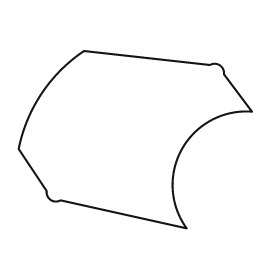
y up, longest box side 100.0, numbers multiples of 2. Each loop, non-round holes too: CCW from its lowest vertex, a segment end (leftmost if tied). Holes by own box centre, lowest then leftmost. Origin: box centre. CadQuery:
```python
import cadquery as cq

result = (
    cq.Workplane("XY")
    .moveTo(22.0, -38.0)
    .threePointArc((20.0, -4.0), (50.0, 12.0))
    .lineTo(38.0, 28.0)
    .threePointArc((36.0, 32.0), (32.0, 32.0))
    .lineTo(-22.0, 38.0)
    .threePointArc((-40.0, 20.0), (-50.0, -4.0))
    .lineTo(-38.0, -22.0)
    .threePointArc((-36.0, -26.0), (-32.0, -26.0))
    .close()
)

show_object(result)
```